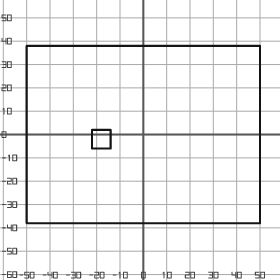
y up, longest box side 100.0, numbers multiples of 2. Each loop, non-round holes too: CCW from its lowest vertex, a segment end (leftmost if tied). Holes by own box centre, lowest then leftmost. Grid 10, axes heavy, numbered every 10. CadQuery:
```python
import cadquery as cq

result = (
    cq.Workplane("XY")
    .moveTo(-50.0, -38.0)
    .lineTo(50.0, -38.0)
    .lineTo(50.0, 38.0)
    .lineTo(-50.0, 38.0)
    .close()
    .moveTo(-22.0, -6.0)
    .lineTo(-14.0, -6.0)
    .lineTo(-14.0, 2.0)
    .lineTo(-22.0, 2.0)
    .close()
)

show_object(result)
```